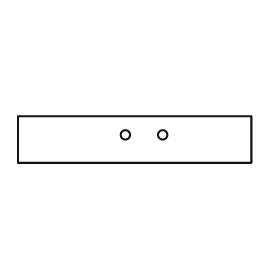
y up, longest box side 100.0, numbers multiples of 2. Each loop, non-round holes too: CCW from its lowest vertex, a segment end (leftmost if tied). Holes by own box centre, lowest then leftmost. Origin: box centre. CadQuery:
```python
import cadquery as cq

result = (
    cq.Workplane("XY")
    .moveTo(-50.0, -10.0)
    .lineTo(50.0, -10.0)
    .lineTo(50.0, 10.0)
    .lineTo(-50.0, 10.0)
    .close()
    .moveTo(-4.0, 2.0)
    .circle(2.0)
    .moveTo(12.0, 2.0)
    .circle(2.0)
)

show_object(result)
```